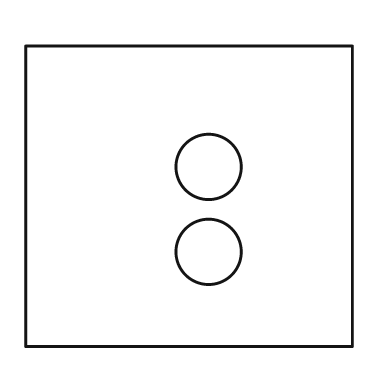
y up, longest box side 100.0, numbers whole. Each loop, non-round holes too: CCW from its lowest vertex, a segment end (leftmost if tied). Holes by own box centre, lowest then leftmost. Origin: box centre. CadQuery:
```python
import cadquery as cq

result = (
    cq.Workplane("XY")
    .moveTo(-50.0, -46.0)
    .lineTo(50.0, -46.0)
    .lineTo(50.0, 46.0)
    .lineTo(-50.0, 46.0)
    .close()
    .moveTo(6.0, -17.0)
    .circle(10.0)
    .moveTo(6.0, 9.0)
    .circle(10.0)
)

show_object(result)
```